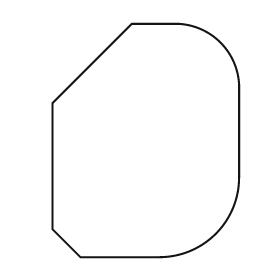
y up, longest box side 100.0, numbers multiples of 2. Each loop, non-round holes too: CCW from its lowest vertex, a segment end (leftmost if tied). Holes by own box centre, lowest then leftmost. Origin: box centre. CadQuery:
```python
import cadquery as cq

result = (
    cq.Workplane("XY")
    .moveTo(-28.0, -50.0)
    .lineTo(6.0, -50.0)
    .threePointArc((30.0, -40.0), (40.0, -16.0))
    .lineTo(40.0, 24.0)
    .threePointArc((32.0, 42.0), (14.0, 50.0))
    .lineTo(-6.0, 50.0)
    .lineTo(-40.0, 16.0)
    .lineTo(-40.0, -38.0)
    .close()
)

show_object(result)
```